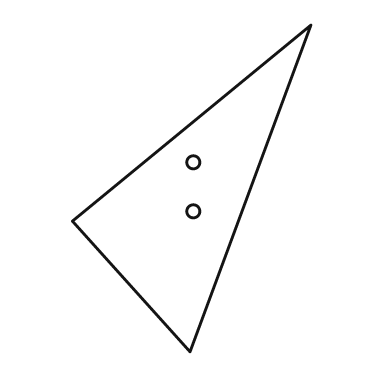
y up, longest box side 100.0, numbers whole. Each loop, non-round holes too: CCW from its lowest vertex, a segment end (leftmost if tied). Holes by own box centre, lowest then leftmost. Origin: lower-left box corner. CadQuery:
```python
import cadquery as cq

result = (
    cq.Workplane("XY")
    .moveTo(36.0, 0.0)
    .lineTo(73.0, 100.0)
    .lineTo(0.0, 40.0)
    .close()
    .moveTo(37.0, 43.0)
    .circle(2.0)
    .moveTo(37.0, 58.0)
    .circle(2.0)
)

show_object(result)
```